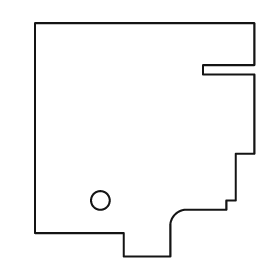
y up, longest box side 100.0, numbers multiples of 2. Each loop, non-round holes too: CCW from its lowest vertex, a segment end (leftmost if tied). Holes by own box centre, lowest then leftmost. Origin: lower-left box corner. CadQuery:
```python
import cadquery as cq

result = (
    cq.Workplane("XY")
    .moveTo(38.0, 0.0)
    .lineTo(58.0, 0.0)
    .lineTo(58.0, 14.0)
    .threePointArc((60.0, 18.0), (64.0, 20.0))
    .lineTo(82.0, 20.0)
    .lineTo(82.0, 24.0)
    .lineTo(86.0, 24.0)
    .lineTo(86.0, 44.0)
    .lineTo(94.0, 44.0)
    .lineTo(94.0, 78.0)
    .lineTo(72.0, 78.0)
    .lineTo(72.0, 82.0)
    .lineTo(94.0, 82.0)
    .lineTo(94.0, 100.0)
    .lineTo(0.0, 100.0)
    .lineTo(0.0, 10.0)
    .lineTo(38.0, 10.0)
    .close()
    .moveTo(28.0, 24.0)
    .circle(4.0)
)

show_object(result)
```